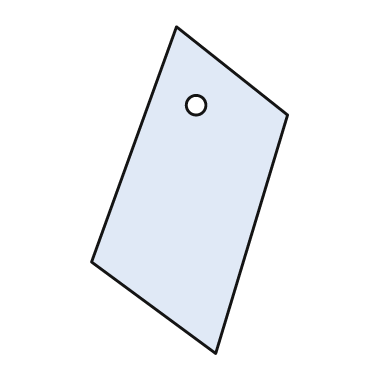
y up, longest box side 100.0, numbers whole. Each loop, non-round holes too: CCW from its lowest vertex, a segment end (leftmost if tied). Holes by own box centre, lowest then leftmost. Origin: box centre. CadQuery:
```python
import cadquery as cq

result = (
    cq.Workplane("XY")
    .moveTo(8.0, -50.0)
    .lineTo(30.0, 23.0)
    .lineTo(-4.0, 50.0)
    .lineTo(-30.0, -22.0)
    .close()
    .moveTo(2.0, 26.0)
    .circle(3.0)
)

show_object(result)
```